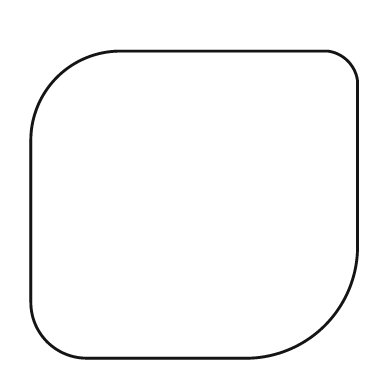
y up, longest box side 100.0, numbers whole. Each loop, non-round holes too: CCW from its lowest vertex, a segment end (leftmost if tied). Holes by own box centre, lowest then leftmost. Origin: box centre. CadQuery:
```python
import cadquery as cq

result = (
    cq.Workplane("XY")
    .moveTo(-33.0, -47.0)
    .lineTo(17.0, -47.0)
    .threePointArc((40.0, -37.0), (50.0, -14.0))
    .lineTo(50.0, 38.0)
    .threePointArc((47.0, 44.0), (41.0, 47.0))
    .lineTo(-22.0, 47.0)
    .threePointArc((-42.0, 39.0), (-50.0, 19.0))
    .lineTo(-50.0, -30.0)
    .threePointArc((-45.0, -42.0), (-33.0, -47.0))
    .close()
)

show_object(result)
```